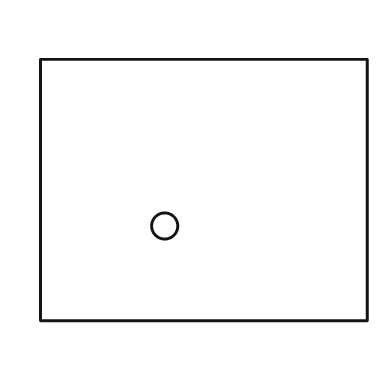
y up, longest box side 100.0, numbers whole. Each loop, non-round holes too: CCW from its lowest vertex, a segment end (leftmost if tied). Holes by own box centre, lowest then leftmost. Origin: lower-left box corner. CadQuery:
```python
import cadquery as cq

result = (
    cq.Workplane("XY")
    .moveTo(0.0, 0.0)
    .lineTo(100.0, 0.0)
    .lineTo(100.0, 80.0)
    .lineTo(0.0, 80.0)
    .close()
    .moveTo(38.0, 29.0)
    .circle(4.0)
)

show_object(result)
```